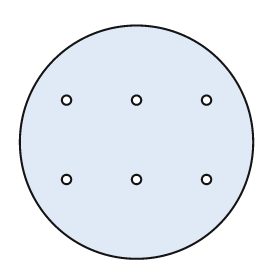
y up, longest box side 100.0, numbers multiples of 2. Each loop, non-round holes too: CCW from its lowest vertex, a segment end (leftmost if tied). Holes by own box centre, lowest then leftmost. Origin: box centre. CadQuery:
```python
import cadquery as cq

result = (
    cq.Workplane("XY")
    .moveTo(0.0, 0.0)
    .circle(50.0)
    .moveTo(-30.0, -16.0)
    .circle(2.0)
    .moveTo(0.0, -16.0)
    .circle(2.0)
    .moveTo(30.0, -16.0)
    .circle(2.0)
    .moveTo(-30.0, 18.0)
    .circle(2.0)
    .moveTo(0.0, 18.0)
    .circle(2.0)
    .moveTo(30.0, 18.0)
    .circle(2.0)
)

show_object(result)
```